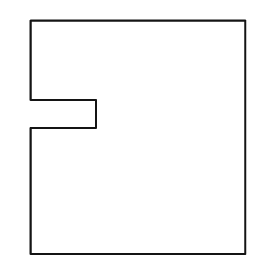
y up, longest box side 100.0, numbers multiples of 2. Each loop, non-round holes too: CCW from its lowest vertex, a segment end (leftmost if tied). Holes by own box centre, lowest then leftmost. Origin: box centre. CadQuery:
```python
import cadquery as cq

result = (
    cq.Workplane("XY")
    .moveTo(-46.0, -50.0)
    .lineTo(46.0, -50.0)
    .lineTo(46.0, 50.0)
    .lineTo(-46.0, 50.0)
    .lineTo(-46.0, 16.0)
    .lineTo(-18.0, 16.0)
    .lineTo(-18.0, 4.0)
    .lineTo(-46.0, 4.0)
    .close()
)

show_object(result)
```